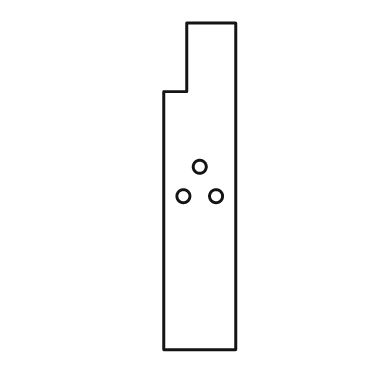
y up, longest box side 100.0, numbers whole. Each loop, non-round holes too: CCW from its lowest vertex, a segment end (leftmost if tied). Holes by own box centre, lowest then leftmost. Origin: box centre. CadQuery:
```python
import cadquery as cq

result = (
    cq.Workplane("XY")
    .moveTo(-11.0, -50.0)
    .lineTo(11.0, -50.0)
    .lineTo(11.0, 50.0)
    .lineTo(-4.0, 50.0)
    .lineTo(-4.0, 29.0)
    .lineTo(-11.0, 29.0)
    .close()
    .moveTo(-5.0, -3.0)
    .circle(2.0)
    .moveTo(5.0, -3.0)
    .circle(2.0)
    .moveTo(0.0, 6.0)
    .circle(2.0)
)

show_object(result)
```